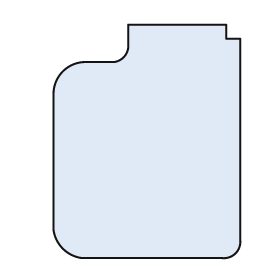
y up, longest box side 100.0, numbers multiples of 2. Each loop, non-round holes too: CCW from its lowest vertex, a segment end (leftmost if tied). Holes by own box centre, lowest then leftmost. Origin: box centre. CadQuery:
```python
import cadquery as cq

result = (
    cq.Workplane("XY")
    .moveTo(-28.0, -50.0)
    .lineTo(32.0, -50.0)
    .threePointArc((38.0, -48.0), (40.0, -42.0))
    .lineTo(40.0, 44.0)
    .lineTo(34.0, 44.0)
    .lineTo(34.0, 50.0)
    .lineTo(-8.0, 50.0)
    .lineTo(-8.0, 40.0)
    .threePointArc((-10.0, 36.0), (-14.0, 34.0))
    .lineTo(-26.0, 34.0)
    .threePointArc((-36.0, 30.0), (-40.0, 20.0))
    .lineTo(-40.0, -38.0)
    .threePointArc((-36.0, -46.0), (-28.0, -50.0))
    .close()
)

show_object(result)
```